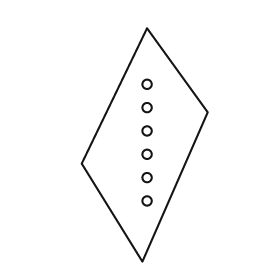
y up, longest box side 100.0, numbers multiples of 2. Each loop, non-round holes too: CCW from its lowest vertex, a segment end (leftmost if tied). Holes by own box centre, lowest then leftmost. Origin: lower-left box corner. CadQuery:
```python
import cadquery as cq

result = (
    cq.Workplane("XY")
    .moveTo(26.0, 0.0)
    .lineTo(54.0, 64.0)
    .lineTo(28.0, 100.0)
    .lineTo(0.0, 42.0)
    .close()
    .moveTo(28.0, 26.0)
    .circle(2.0)
    .moveTo(28.0, 36.0)
    .circle(2.0)
    .moveTo(28.0, 46.0)
    .circle(2.0)
    .moveTo(28.0, 56.0)
    .circle(2.0)
    .moveTo(28.0, 66.0)
    .circle(2.0)
    .moveTo(28.0, 76.0)
    .circle(2.0)
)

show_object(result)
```